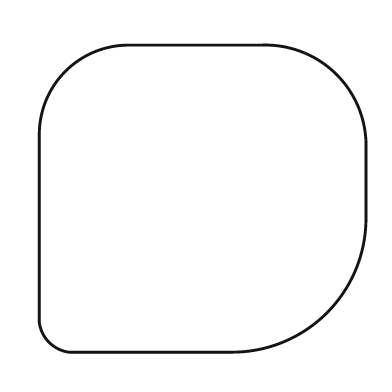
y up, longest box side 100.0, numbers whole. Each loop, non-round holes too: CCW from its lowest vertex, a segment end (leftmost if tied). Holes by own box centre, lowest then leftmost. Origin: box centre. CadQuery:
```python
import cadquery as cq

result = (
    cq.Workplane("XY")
    .moveTo(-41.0, -47.0)
    .lineTo(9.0, -47.0)
    .threePointArc((38.0, -35.0), (50.0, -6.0))
    .lineTo(50.0, 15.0)
    .threePointArc((41.0, 38.0), (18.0, 47.0))
    .lineTo(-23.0, 47.0)
    .threePointArc((-42.0, 39.0), (-50.0, 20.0))
    .lineTo(-50.0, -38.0)
    .threePointArc((-47.0, -44.0), (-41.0, -47.0))
    .close()
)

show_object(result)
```